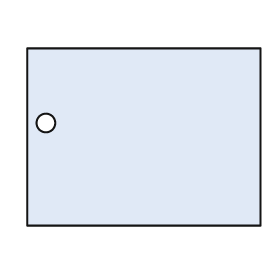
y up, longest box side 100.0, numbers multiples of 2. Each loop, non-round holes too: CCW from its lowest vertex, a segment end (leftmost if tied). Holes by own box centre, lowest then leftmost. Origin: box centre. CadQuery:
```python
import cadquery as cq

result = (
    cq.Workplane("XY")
    .moveTo(-50.0, -38.0)
    .lineTo(50.0, -38.0)
    .lineTo(50.0, 38.0)
    .lineTo(-50.0, 38.0)
    .close()
    .moveTo(-42.0, 6.0)
    .circle(4.0)
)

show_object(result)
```